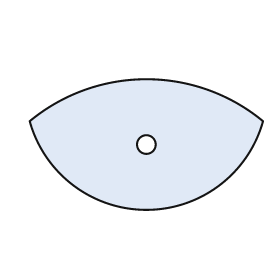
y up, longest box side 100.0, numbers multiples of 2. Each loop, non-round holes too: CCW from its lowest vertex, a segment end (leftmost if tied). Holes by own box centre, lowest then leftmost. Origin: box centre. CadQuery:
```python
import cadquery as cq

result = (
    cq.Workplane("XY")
    .moveTo(-50.0, 10.0)
    .threePointArc((0.0, -28.0), (50.0, 10.0))
    .threePointArc((0.0, 28.0), (-50.0, 10.0))
    .close()
    .moveTo(0.0, 0.0)
    .circle(4.0)
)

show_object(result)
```